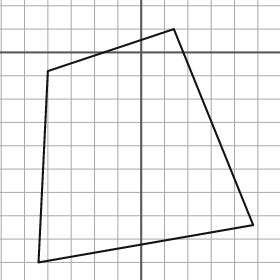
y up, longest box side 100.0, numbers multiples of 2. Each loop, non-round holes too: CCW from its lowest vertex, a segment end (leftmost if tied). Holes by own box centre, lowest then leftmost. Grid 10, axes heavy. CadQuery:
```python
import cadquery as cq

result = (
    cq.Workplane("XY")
    .moveTo(-44.0, -90.0)
    .lineTo(48.0, -74.0)
    .lineTo(14.0, 10.0)
    .lineTo(-40.0, -8.0)
    .close()
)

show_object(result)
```